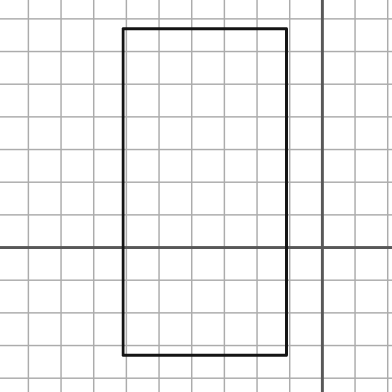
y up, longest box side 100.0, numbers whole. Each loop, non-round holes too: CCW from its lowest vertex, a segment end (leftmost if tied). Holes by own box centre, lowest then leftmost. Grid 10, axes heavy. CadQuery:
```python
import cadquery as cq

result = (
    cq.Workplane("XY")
    .moveTo(-61.0, -33.0)
    .lineTo(-11.0, -33.0)
    .lineTo(-11.0, 67.0)
    .lineTo(-61.0, 67.0)
    .close()
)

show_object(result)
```